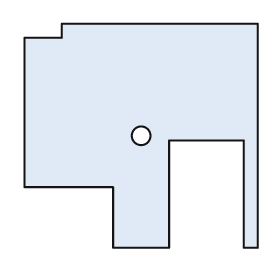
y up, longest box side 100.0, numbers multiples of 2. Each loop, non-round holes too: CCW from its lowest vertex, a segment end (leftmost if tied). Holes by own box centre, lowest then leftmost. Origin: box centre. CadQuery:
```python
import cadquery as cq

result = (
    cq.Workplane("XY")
    .moveTo(-12.0, -48.0)
    .lineTo(12.0, -48.0)
    .lineTo(12.0, -2.0)
    .lineTo(44.0, -2.0)
    .lineTo(44.0, -48.0)
    .lineTo(50.0, -48.0)
    .lineTo(50.0, 48.0)
    .lineTo(-34.0, 48.0)
    .lineTo(-34.0, 42.0)
    .lineTo(-50.0, 42.0)
    .lineTo(-50.0, -22.0)
    .lineTo(-12.0, -22.0)
    .close()
    .moveTo(0.0, 0.0)
    .circle(4.0)
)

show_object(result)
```